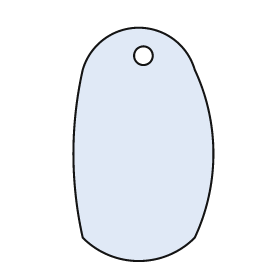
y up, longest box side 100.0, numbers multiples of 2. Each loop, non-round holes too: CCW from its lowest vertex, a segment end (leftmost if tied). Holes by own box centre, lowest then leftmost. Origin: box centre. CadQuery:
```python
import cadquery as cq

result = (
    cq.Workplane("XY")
    .moveTo(-26.0, -40.0)
    .threePointArc((-2.0, -50.0), (22.0, -40.0))
    .threePointArc((30.0, -4.0), (22.0, 32.0))
    .threePointArc((-2.0, 50.0), (-26.0, 32.0))
    .threePointArc((-30.0, -4.0), (-26.0, -40.0))
    .close()
    .moveTo(0.0, 38.0)
    .circle(4.0)
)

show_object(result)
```